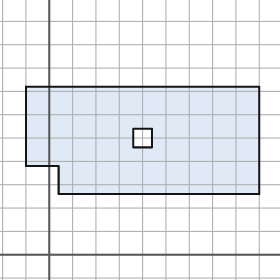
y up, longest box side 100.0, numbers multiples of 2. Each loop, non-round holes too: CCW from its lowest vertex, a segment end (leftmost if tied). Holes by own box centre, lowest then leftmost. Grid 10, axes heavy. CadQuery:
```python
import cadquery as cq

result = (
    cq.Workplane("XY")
    .moveTo(4.0, 26.0)
    .lineTo(90.0, 26.0)
    .lineTo(90.0, 72.0)
    .lineTo(-10.0, 72.0)
    .lineTo(-10.0, 38.0)
    .lineTo(4.0, 38.0)
    .close()
    .moveTo(36.0, 46.0)
    .lineTo(44.0, 46.0)
    .lineTo(44.0, 54.0)
    .lineTo(36.0, 54.0)
    .close()
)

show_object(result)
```